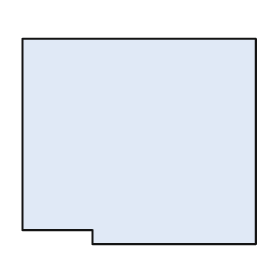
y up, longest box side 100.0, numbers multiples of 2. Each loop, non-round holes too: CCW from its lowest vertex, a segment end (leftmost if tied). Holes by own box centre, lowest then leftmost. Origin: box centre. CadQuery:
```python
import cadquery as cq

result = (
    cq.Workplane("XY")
    .moveTo(-20.0, -44.0)
    .lineTo(50.0, -44.0)
    .lineTo(50.0, 44.0)
    .lineTo(-50.0, 44.0)
    .lineTo(-50.0, -38.0)
    .lineTo(-20.0, -38.0)
    .close()
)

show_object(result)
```